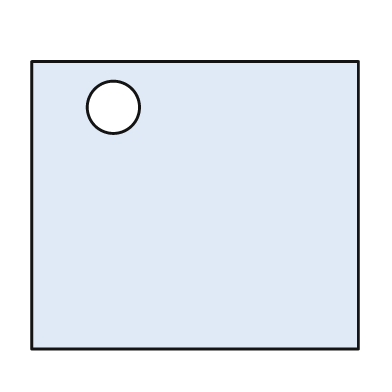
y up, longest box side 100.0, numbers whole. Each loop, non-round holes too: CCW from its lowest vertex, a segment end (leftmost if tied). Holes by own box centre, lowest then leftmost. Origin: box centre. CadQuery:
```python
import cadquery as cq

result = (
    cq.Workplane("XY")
    .moveTo(-50.0, -44.0)
    .lineTo(50.0, -44.0)
    .lineTo(50.0, 44.0)
    .lineTo(-50.0, 44.0)
    .close()
    .moveTo(-25.0, 30.0)
    .circle(8.0)
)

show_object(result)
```